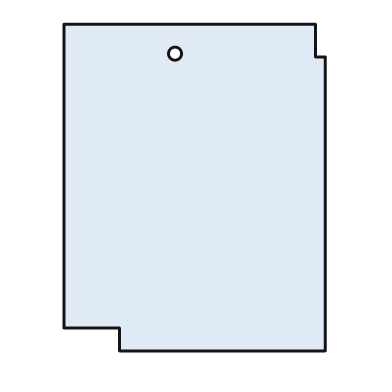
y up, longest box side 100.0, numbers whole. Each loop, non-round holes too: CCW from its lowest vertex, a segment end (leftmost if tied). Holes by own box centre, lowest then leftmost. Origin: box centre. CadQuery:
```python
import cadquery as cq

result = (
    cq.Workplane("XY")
    .moveTo(-23.0, -50.0)
    .lineTo(40.0, -50.0)
    .lineTo(40.0, 40.0)
    .lineTo(37.0, 40.0)
    .lineTo(37.0, 50.0)
    .lineTo(-40.0, 50.0)
    .lineTo(-40.0, -43.0)
    .lineTo(-23.0, -43.0)
    .close()
    .moveTo(-6.0, 41.0)
    .circle(2.0)
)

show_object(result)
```